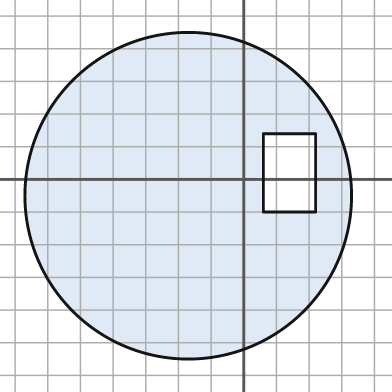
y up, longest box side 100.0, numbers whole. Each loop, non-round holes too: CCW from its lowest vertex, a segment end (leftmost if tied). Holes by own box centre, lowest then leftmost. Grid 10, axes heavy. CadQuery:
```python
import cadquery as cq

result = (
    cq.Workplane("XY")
    .moveTo(-17.0, -5.0)
    .circle(50.0)
    .moveTo(6.0, -10.0)
    .lineTo(22.0, -10.0)
    .lineTo(22.0, 14.0)
    .lineTo(6.0, 14.0)
    .close()
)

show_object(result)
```